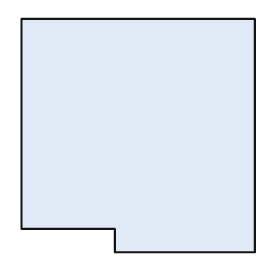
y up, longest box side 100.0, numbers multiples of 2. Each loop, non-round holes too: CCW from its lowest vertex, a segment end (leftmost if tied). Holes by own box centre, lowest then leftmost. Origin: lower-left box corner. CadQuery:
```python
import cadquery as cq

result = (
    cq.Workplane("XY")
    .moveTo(40.0, 0.0)
    .lineTo(100.0, 0.0)
    .lineTo(100.0, 100.0)
    .lineTo(0.0, 100.0)
    .lineTo(0.0, 10.0)
    .lineTo(40.0, 10.0)
    .close()
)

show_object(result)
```